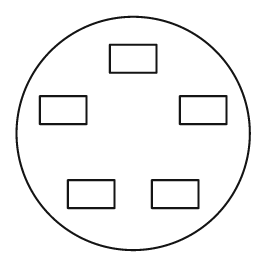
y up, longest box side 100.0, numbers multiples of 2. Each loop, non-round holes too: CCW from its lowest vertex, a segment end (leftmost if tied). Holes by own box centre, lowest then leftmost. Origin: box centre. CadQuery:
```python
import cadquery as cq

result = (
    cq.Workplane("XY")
    .moveTo(0.0, 0.0)
    .circle(50.0)
    .moveTo(-28.0, -32.0)
    .lineTo(-8.0, -32.0)
    .lineTo(-8.0, -20.0)
    .lineTo(-28.0, -20.0)
    .close()
    .moveTo(8.0, -32.0)
    .lineTo(28.0, -32.0)
    .lineTo(28.0, -20.0)
    .lineTo(8.0, -20.0)
    .close()
    .moveTo(-40.0, 4.0)
    .lineTo(-20.0, 4.0)
    .lineTo(-20.0, 16.0)
    .lineTo(-40.0, 16.0)
    .close()
    .moveTo(20.0, 4.0)
    .lineTo(40.0, 4.0)
    .lineTo(40.0, 16.0)
    .lineTo(20.0, 16.0)
    .close()
    .moveTo(-10.0, 26.0)
    .lineTo(10.0, 26.0)
    .lineTo(10.0, 38.0)
    .lineTo(-10.0, 38.0)
    .close()
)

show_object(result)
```